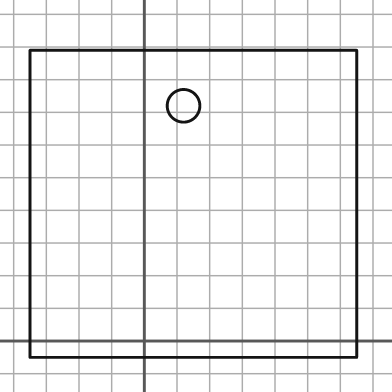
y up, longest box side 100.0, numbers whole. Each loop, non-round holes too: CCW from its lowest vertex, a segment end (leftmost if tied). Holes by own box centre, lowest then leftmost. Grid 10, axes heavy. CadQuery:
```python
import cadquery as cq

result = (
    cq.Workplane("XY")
    .moveTo(-35.0, -5.0)
    .lineTo(65.0, -5.0)
    .lineTo(65.0, 89.0)
    .lineTo(-35.0, 89.0)
    .close()
    .moveTo(12.0, 72.0)
    .circle(5.0)
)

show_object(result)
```